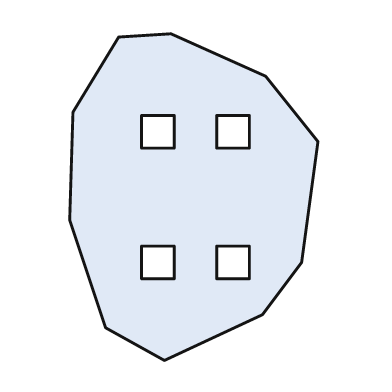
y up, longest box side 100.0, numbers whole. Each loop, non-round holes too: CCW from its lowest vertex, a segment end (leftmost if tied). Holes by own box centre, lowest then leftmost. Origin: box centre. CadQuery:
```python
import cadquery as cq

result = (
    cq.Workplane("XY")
    .moveTo(-9.0, -50.0)
    .lineTo(21.0, -36.0)
    .lineTo(33.0, -20.0)
    .lineTo(38.0, 17.0)
    .lineTo(22.0, 37.0)
    .lineTo(-7.0, 50.0)
    .lineTo(-23.0, 49.0)
    .lineTo(-37.0, 26.0)
    .lineTo(-38.0, -7.0)
    .lineTo(-27.0, -40.0)
    .close()
    .moveTo(-16.0, -25.0)
    .lineTo(-6.0, -25.0)
    .lineTo(-6.0, -15.0)
    .lineTo(-16.0, -15.0)
    .close()
    .moveTo(7.0, -25.0)
    .lineTo(17.0, -25.0)
    .lineTo(17.0, -15.0)
    .lineTo(7.0, -15.0)
    .close()
    .moveTo(-16.0, 15.0)
    .lineTo(-6.0, 15.0)
    .lineTo(-6.0, 25.0)
    .lineTo(-16.0, 25.0)
    .close()
    .moveTo(7.0, 15.0)
    .lineTo(17.0, 15.0)
    .lineTo(17.0, 25.0)
    .lineTo(7.0, 25.0)
    .close()
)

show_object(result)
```